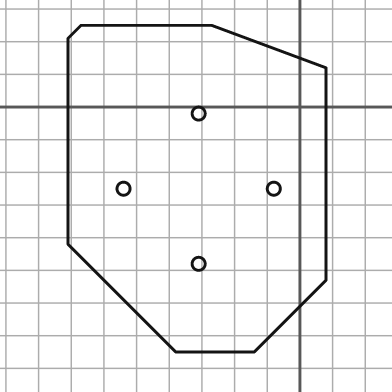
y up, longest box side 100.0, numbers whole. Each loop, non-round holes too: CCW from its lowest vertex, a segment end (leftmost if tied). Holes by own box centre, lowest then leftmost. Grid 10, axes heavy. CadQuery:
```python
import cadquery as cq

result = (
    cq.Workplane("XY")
    .moveTo(-38.0, -75.0)
    .lineTo(-14.0, -75.0)
    .lineTo(8.0, -53.0)
    .lineTo(8.0, 12.0)
    .lineTo(-27.0, 25.0)
    .lineTo(-67.0, 25.0)
    .lineTo(-71.0, 21.0)
    .lineTo(-71.0, -42.0)
    .close()
    .moveTo(-31.0, -48.0)
    .circle(2.0)
    .moveTo(-54.0, -25.0)
    .circle(2.0)
    .moveTo(-8.0, -25.0)
    .circle(2.0)
    .moveTo(-31.0, -2.0)
    .circle(2.0)
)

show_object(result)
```